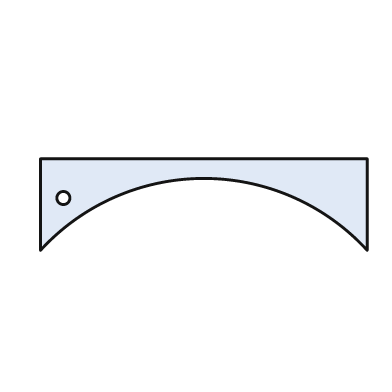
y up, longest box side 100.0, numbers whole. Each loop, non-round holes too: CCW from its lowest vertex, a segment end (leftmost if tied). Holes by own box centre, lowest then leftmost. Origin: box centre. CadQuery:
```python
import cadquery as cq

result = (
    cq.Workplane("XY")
    .moveTo(-50.0, -14.0)
    .threePointArc((0.0, 8.0), (50.0, -14.0))
    .lineTo(50.0, 14.0)
    .lineTo(-50.0, 14.0)
    .close()
    .moveTo(-43.0, 2.0)
    .circle(2.0)
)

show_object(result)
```